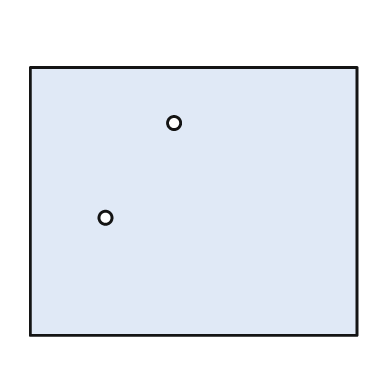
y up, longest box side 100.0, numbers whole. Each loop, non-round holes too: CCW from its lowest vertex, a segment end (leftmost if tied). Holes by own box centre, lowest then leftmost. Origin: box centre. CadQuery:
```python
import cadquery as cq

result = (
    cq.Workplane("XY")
    .moveTo(-50.0, -41.0)
    .lineTo(50.0, -41.0)
    .lineTo(50.0, 41.0)
    .lineTo(-50.0, 41.0)
    .close()
    .moveTo(-27.0, -5.0)
    .circle(2.0)
    .moveTo(-6.0, 24.0)
    .circle(2.0)
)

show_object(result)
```